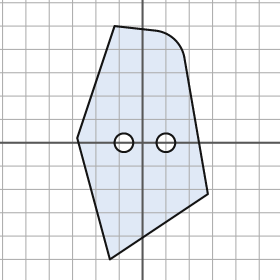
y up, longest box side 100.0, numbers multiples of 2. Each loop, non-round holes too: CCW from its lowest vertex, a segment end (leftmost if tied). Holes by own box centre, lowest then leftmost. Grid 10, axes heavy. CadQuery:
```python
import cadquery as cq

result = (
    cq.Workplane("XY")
    .moveTo(-14.0, -50.0)
    .lineTo(28.0, -22.0)
    .lineTo(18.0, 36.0)
    .threePointArc((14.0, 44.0), (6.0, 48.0))
    .lineTo(-12.0, 50.0)
    .lineTo(-28.0, 2.0)
    .close()
    .moveTo(-8.0, 0.0)
    .circle(4.0)
    .moveTo(10.0, 0.0)
    .circle(4.0)
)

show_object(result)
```